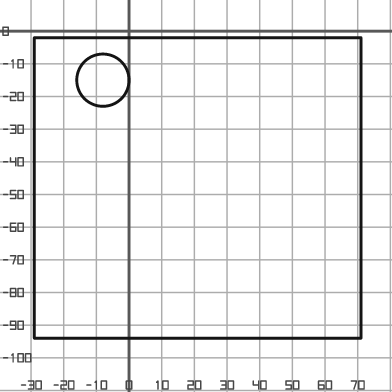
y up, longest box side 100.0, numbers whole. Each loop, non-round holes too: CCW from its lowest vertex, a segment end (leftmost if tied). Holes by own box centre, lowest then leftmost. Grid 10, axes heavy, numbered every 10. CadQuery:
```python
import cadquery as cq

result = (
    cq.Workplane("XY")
    .moveTo(-29.0, -94.0)
    .lineTo(71.0, -94.0)
    .lineTo(71.0, -2.0)
    .lineTo(-29.0, -2.0)
    .close()
    .moveTo(-8.0, -15.0)
    .circle(8.0)
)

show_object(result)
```